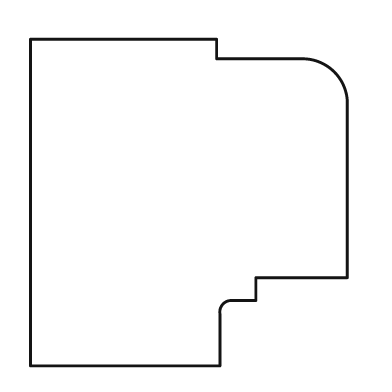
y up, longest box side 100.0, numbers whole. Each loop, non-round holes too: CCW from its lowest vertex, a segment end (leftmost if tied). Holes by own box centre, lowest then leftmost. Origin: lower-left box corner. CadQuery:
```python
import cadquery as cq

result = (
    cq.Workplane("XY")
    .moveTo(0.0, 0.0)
    .lineTo(58.0, 0.0)
    .lineTo(58.0, 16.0)
    .threePointArc((59.0, 19.0), (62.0, 20.0))
    .lineTo(69.0, 20.0)
    .lineTo(69.0, 27.0)
    .lineTo(97.0, 27.0)
    .lineTo(97.0, 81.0)
    .threePointArc((93.0, 90.0), (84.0, 94.0))
    .lineTo(57.0, 94.0)
    .lineTo(57.0, 100.0)
    .lineTo(0.0, 100.0)
    .close()
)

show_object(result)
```